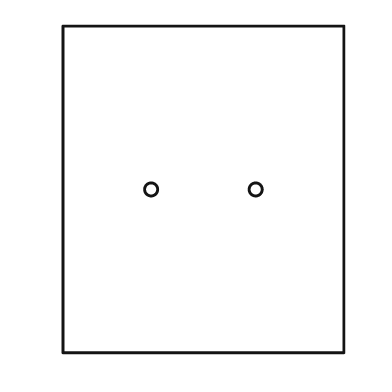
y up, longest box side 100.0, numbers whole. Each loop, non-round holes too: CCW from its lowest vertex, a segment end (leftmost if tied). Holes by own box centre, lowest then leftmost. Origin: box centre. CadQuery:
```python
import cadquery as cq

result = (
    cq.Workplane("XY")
    .moveTo(-43.0, -50.0)
    .lineTo(43.0, -50.0)
    .lineTo(43.0, 50.0)
    .lineTo(-43.0, 50.0)
    .close()
    .moveTo(-16.0, 0.0)
    .circle(2.0)
    .moveTo(16.0, 0.0)
    .circle(2.0)
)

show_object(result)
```